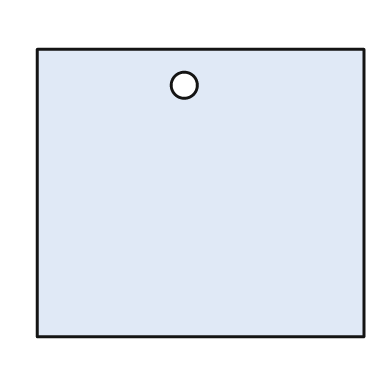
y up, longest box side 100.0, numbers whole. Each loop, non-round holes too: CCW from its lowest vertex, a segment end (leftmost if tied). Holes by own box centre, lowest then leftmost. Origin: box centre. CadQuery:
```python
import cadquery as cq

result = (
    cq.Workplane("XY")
    .moveTo(-50.0, -44.0)
    .lineTo(50.0, -44.0)
    .lineTo(50.0, 44.0)
    .lineTo(-50.0, 44.0)
    .close()
    .moveTo(-5.0, 33.0)
    .circle(4.0)
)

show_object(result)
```